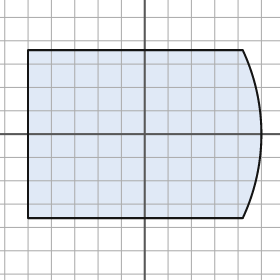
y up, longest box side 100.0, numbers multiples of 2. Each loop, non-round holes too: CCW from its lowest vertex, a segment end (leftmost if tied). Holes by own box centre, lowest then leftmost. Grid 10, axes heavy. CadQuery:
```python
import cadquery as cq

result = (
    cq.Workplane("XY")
    .moveTo(-50.0, -36.0)
    .lineTo(42.0, -36.0)
    .threePointArc((50.0, 0.0), (42.0, 36.0))
    .lineTo(-50.0, 36.0)
    .close()
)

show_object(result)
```